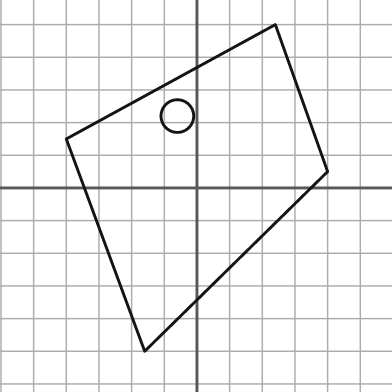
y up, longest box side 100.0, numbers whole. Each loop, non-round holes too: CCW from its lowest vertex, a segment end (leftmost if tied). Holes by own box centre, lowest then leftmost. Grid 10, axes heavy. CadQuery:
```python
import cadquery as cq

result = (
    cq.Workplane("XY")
    .moveTo(-16.0, -50.0)
    .lineTo(40.0, 5.0)
    .lineTo(24.0, 50.0)
    .lineTo(-40.0, 15.0)
    .close()
    .moveTo(-6.0, 22.0)
    .circle(5.0)
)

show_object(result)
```